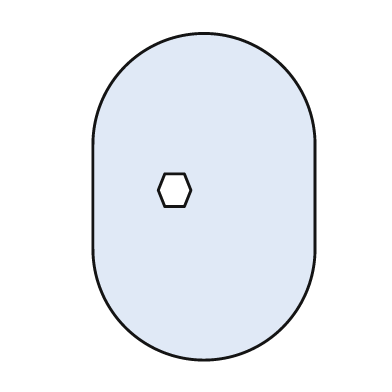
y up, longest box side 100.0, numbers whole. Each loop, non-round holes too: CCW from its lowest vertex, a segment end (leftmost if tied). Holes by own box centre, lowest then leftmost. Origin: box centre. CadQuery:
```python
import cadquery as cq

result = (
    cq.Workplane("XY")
    .moveTo(-34.0, -16.0)
    .threePointArc((0.0, -50.0), (34.0, -16.0))
    .lineTo(34.0, 16.0)
    .threePointArc((0.0, 50.0), (-34.0, 16.0))
    .close()
    .moveTo(-12.0, -3.0)
    .lineTo(-6.0, -3.0)
    .lineTo(-4.0, 2.0)
    .lineTo(-6.0, 7.0)
    .lineTo(-12.0, 7.0)
    .lineTo(-14.0, 2.0)
    .close()
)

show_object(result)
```